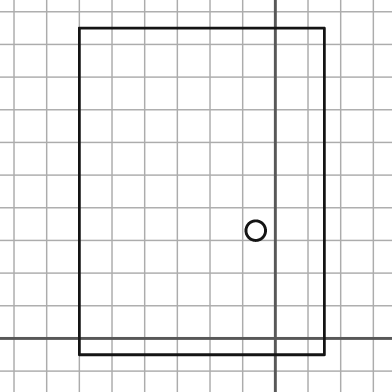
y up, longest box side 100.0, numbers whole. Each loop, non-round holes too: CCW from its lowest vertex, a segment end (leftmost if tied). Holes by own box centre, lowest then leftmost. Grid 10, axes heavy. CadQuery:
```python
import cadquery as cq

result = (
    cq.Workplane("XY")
    .moveTo(-60.0, -5.0)
    .lineTo(15.0, -5.0)
    .lineTo(15.0, 95.0)
    .lineTo(-60.0, 95.0)
    .close()
    .moveTo(-6.0, 33.0)
    .circle(3.0)
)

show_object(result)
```